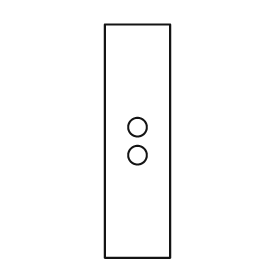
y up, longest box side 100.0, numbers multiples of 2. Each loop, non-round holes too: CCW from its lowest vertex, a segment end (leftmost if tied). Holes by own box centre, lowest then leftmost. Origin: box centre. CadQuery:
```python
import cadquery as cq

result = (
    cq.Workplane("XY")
    .moveTo(-14.0, -50.0)
    .lineTo(14.0, -50.0)
    .lineTo(14.0, 50.0)
    .lineTo(-14.0, 50.0)
    .close()
    .moveTo(0.0, -6.0)
    .circle(4.0)
    .moveTo(0.0, 6.0)
    .circle(4.0)
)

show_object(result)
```